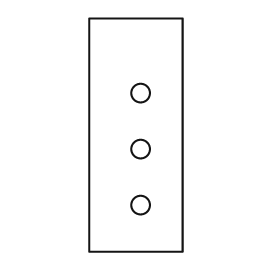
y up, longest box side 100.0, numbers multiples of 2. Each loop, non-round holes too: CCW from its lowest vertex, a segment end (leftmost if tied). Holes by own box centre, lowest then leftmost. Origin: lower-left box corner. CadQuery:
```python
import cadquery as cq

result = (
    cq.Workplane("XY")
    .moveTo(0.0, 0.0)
    .lineTo(40.0, 0.0)
    .lineTo(40.0, 100.0)
    .lineTo(0.0, 100.0)
    .close()
    .moveTo(22.0, 20.0)
    .circle(4.0)
    .moveTo(22.0, 44.0)
    .circle(4.0)
    .moveTo(22.0, 68.0)
    .circle(4.0)
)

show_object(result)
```